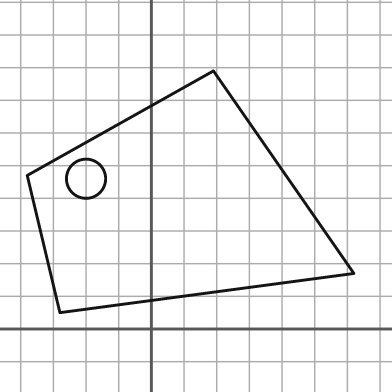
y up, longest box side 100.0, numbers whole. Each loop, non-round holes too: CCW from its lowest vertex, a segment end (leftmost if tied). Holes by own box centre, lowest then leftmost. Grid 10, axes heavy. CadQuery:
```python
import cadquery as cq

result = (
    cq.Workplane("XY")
    .moveTo(-28.0, 5.0)
    .lineTo(62.0, 17.0)
    .lineTo(19.0, 79.0)
    .lineTo(-38.0, 47.0)
    .close()
    .moveTo(-20.0, 46.0)
    .circle(6.0)
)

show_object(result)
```